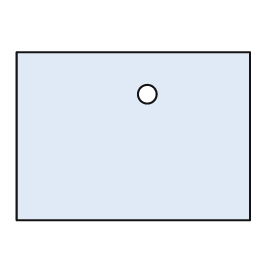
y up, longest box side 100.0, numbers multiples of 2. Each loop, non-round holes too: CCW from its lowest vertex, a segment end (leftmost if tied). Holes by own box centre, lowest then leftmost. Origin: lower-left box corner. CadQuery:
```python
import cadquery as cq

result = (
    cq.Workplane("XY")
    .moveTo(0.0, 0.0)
    .lineTo(100.0, 0.0)
    .lineTo(100.0, 72.0)
    .lineTo(0.0, 72.0)
    .close()
    .moveTo(56.0, 54.0)
    .circle(4.0)
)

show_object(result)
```